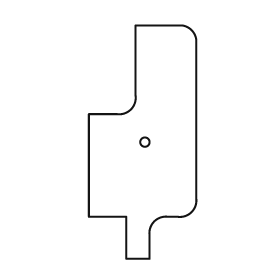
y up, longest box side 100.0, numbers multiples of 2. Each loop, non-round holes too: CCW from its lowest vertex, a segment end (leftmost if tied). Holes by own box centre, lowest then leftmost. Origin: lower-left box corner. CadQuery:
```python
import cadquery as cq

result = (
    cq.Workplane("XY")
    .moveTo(16.0, 0.0)
    .lineTo(26.0, 0.0)
    .lineTo(26.0, 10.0)
    .threePointArc((28.0, 16.0), (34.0, 18.0))
    .lineTo(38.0, 18.0)
    .threePointArc((44.0, 20.0), (46.0, 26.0))
    .lineTo(46.0, 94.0)
    .threePointArc((44.0, 98.0), (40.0, 100.0))
    .lineTo(20.0, 100.0)
    .lineTo(20.0, 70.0)
    .threePointArc((18.0, 64.0), (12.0, 62.0))
    .lineTo(0.0, 62.0)
    .lineTo(0.0, 18.0)
    .lineTo(16.0, 18.0)
    .close()
    .moveTo(24.0, 50.0)
    .circle(2.0)
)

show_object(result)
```